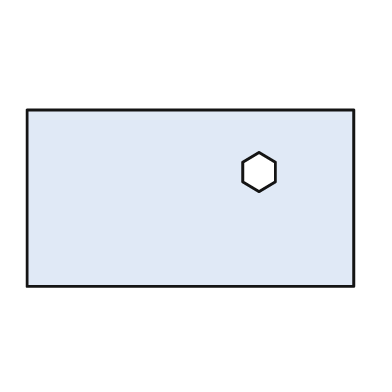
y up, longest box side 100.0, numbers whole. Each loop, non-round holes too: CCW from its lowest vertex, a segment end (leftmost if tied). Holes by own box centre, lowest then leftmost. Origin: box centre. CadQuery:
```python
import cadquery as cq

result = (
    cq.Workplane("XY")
    .moveTo(-50.0, -27.0)
    .lineTo(50.0, -27.0)
    .lineTo(50.0, 27.0)
    .lineTo(-50.0, 27.0)
    .close()
    .moveTo(21.0, 2.0)
    .lineTo(26.0, 5.0)
    .lineTo(26.0, 11.0)
    .lineTo(21.0, 14.0)
    .lineTo(16.0, 11.0)
    .lineTo(16.0, 5.0)
    .close()
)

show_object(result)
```